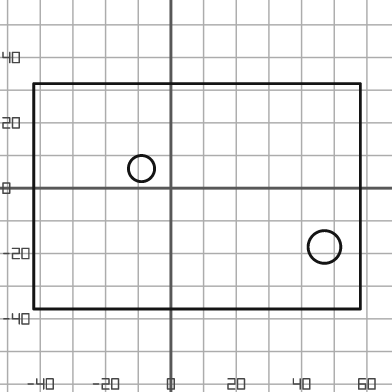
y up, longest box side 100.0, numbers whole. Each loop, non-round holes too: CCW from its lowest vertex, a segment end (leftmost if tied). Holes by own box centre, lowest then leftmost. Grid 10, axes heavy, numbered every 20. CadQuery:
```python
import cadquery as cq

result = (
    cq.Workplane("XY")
    .moveTo(-42.0, -37.0)
    .lineTo(58.0, -37.0)
    .lineTo(58.0, 32.0)
    .lineTo(-42.0, 32.0)
    .close()
    .moveTo(47.0, -18.0)
    .circle(5.0)
    .moveTo(-9.0, 6.0)
    .circle(4.0)
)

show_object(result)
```